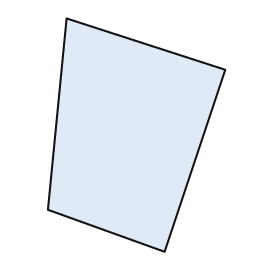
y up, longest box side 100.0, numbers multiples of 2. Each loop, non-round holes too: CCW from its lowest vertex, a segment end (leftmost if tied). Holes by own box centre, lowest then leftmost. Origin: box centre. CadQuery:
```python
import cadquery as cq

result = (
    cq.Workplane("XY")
    .moveTo(12.0, -50.0)
    .lineTo(38.0, 28.0)
    .lineTo(-30.0, 50.0)
    .lineTo(-38.0, -32.0)
    .close()
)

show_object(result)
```